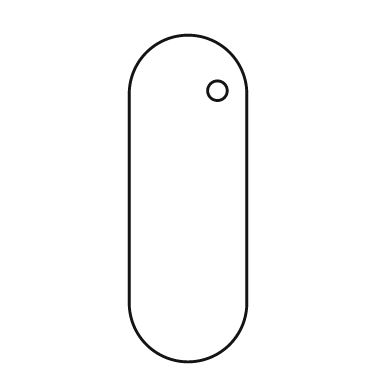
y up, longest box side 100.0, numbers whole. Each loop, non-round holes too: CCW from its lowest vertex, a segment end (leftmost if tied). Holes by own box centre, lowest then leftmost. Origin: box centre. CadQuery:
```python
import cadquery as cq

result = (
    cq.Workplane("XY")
    .moveTo(-18.0, -32.0)
    .threePointArc((0.0, -50.0), (18.0, -32.0))
    .lineTo(18.0, 32.0)
    .threePointArc((0.0, 50.0), (-18.0, 32.0))
    .close()
    .moveTo(9.0, 33.0)
    .circle(3.0)
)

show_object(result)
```